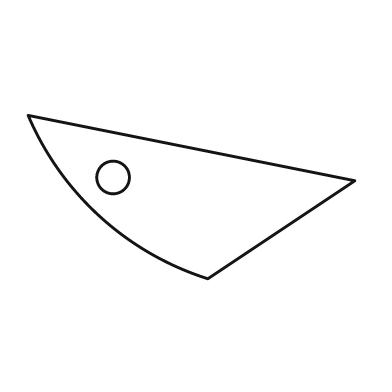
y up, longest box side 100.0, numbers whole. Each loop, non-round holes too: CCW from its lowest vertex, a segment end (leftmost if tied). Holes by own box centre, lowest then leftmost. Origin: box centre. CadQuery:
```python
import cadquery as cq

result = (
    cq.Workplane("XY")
    .moveTo(5.0, -25.0)
    .lineTo(50.0, 5.0)
    .lineTo(-50.0, 25.0)
    .threePointArc((-28.0, -6.0), (5.0, -25.0))
    .close()
    .moveTo(-24.0, 6.0)
    .circle(5.0)
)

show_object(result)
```